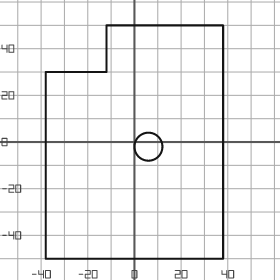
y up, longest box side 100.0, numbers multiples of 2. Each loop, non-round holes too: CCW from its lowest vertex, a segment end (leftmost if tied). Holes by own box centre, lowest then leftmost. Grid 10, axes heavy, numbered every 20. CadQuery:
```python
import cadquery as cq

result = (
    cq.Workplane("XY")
    .moveTo(-38.0, -50.0)
    .lineTo(38.0, -50.0)
    .lineTo(38.0, 50.0)
    .lineTo(-12.0, 50.0)
    .lineTo(-12.0, 30.0)
    .lineTo(-38.0, 30.0)
    .close()
    .moveTo(6.0, -2.0)
    .circle(6.0)
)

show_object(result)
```